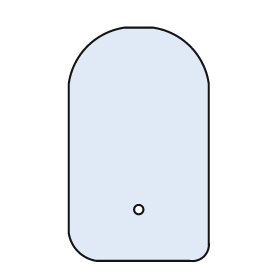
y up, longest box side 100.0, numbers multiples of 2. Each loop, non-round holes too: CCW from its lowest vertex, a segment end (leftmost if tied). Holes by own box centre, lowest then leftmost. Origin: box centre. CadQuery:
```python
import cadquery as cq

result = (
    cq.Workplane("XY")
    .moveTo(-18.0, -50.0)
    .lineTo(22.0, -50.0)
    .threePointArc((28.0, -48.0), (30.0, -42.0))
    .lineTo(30.0, 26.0)
    .threePointArc((22.0, 42.0), (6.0, 50.0))
    .lineTo(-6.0, 50.0)
    .threePointArc((-22.0, 42.0), (-30.0, 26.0))
    .lineTo(-30.0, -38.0)
    .threePointArc((-26.0, -46.0), (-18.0, -50.0))
    .close()
    .moveTo(0.0, -28.0)
    .circle(2.0)
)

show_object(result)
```